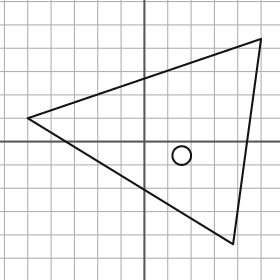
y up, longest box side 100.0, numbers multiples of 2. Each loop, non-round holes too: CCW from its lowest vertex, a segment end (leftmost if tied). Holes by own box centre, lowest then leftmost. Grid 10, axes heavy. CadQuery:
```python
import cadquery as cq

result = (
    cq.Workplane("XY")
    .moveTo(38.0, -44.0)
    .lineTo(50.0, 44.0)
    .lineTo(-50.0, 10.0)
    .close()
    .moveTo(16.0, -6.0)
    .circle(4.0)
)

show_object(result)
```